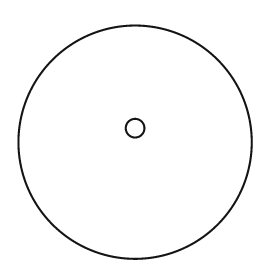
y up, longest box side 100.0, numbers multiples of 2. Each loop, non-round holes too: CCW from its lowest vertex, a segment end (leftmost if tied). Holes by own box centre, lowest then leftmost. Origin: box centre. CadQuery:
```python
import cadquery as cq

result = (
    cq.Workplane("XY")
    .moveTo(0.0, 0.0)
    .circle(50.0)
    .moveTo(0.0, 6.0)
    .circle(4.0)
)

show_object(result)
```